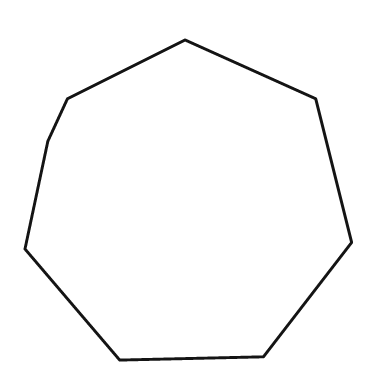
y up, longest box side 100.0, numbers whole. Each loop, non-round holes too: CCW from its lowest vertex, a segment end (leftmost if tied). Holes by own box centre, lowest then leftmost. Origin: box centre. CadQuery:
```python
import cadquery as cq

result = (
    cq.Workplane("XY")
    .moveTo(-21.0, -49.0)
    .lineTo(23.0, -48.0)
    .lineTo(50.0, -13.0)
    .lineTo(39.0, 31.0)
    .lineTo(-1.0, 49.0)
    .lineTo(-37.0, 31.0)
    .lineTo(-43.0, 18.0)
    .lineTo(-50.0, -15.0)
    .close()
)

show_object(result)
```